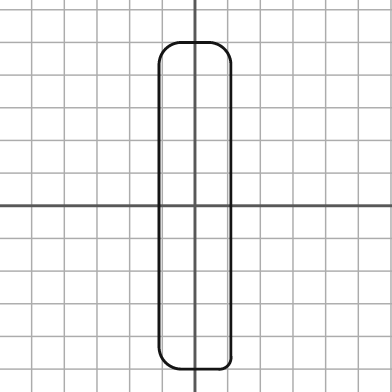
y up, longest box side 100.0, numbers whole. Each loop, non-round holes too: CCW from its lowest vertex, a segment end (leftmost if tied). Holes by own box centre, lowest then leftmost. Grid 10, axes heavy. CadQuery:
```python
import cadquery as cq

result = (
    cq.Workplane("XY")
    .moveTo(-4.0, -50.0)
    .lineTo(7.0, -50.0)
    .threePointArc((10.0, -49.0), (11.0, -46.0))
    .lineTo(11.0, 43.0)
    .threePointArc((9.0, 48.0), (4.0, 50.0))
    .lineTo(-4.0, 50.0)
    .threePointArc((-9.0, 48.0), (-11.0, 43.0))
    .lineTo(-11.0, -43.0)
    .threePointArc((-9.0, -48.0), (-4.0, -50.0))
    .close()
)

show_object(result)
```